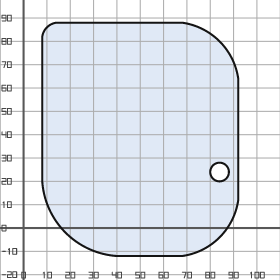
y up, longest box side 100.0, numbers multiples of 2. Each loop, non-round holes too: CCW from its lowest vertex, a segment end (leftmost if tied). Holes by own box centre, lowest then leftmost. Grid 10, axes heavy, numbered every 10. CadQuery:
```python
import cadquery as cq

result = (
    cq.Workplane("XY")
    .moveTo(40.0, -12.0)
    .lineTo(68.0, -12.0)
    .threePointArc((84.0, -4.0), (92.0, 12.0))
    .lineTo(92.0, 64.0)
    .threePointArc((84.0, 80.0), (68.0, 88.0))
    .lineTo(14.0, 88.0)
    .threePointArc((10.0, 86.0), (8.0, 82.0))
    .lineTo(8.0, 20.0)
    .threePointArc((18.0, -2.0), (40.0, -12.0))
    .close()
    .moveTo(84.0, 24.0)
    .circle(4.0)
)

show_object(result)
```